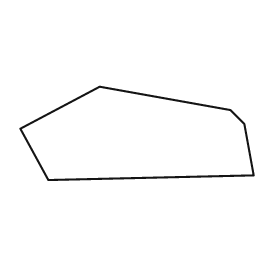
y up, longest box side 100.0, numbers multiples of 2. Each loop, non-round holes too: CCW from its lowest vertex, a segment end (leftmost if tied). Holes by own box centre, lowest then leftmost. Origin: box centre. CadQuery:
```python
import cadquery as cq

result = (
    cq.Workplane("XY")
    .moveTo(-38.0, -20.0)
    .lineTo(50.0, -18.0)
    .lineTo(46.0, 4.0)
    .lineTo(40.0, 10.0)
    .lineTo(-16.0, 20.0)
    .lineTo(-50.0, 2.0)
    .close()
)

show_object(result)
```